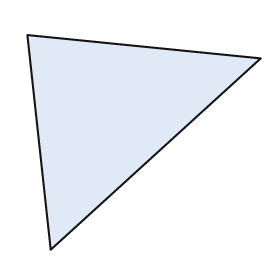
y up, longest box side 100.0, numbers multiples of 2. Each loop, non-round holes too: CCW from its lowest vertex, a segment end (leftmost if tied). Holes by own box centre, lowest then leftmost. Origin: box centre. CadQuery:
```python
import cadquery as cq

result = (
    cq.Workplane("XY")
    .moveTo(-40.0, -46.0)
    .lineTo(50.0, 36.0)
    .lineTo(-50.0, 46.0)
    .close()
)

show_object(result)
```